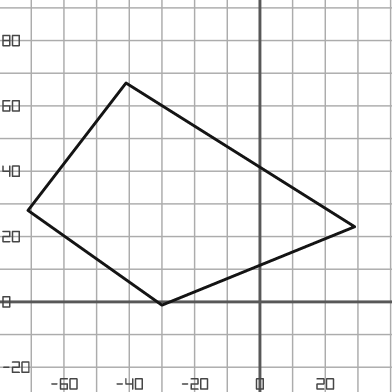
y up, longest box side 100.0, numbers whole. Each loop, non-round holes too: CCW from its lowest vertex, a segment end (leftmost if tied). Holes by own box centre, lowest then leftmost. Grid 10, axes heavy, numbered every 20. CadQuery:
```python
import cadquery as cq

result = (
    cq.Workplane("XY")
    .moveTo(-30.0, -1.0)
    .lineTo(29.0, 23.0)
    .lineTo(-41.0, 67.0)
    .lineTo(-71.0, 28.0)
    .close()
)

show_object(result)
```